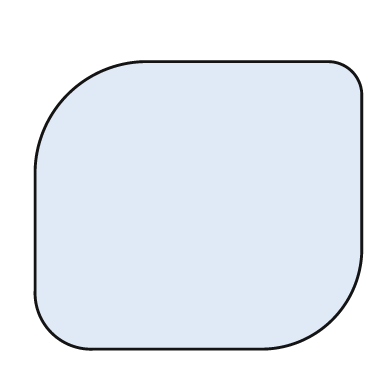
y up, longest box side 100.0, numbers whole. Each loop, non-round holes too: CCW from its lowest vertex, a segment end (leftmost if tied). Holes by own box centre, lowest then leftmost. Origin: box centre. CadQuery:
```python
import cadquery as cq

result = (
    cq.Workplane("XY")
    .moveTo(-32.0, -44.0)
    .lineTo(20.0, -44.0)
    .threePointArc((41.0, -35.0), (50.0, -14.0))
    .lineTo(50.0, 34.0)
    .threePointArc((47.0, 41.0), (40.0, 44.0))
    .lineTo(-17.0, 44.0)
    .threePointArc((-40.0, 34.0), (-50.0, 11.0))
    .lineTo(-50.0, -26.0)
    .threePointArc((-45.0, -39.0), (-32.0, -44.0))
    .close()
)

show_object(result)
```